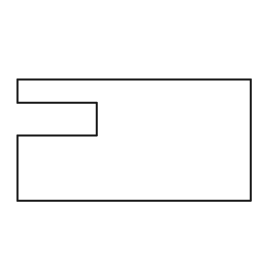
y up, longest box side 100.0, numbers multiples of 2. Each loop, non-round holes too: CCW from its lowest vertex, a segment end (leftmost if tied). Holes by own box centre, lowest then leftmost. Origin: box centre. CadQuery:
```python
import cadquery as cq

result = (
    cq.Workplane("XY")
    .moveTo(-50.0, -26.0)
    .lineTo(50.0, -26.0)
    .lineTo(50.0, 26.0)
    .lineTo(-50.0, 26.0)
    .lineTo(-50.0, 16.0)
    .lineTo(-16.0, 16.0)
    .lineTo(-16.0, 2.0)
    .lineTo(-50.0, 2.0)
    .close()
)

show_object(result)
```